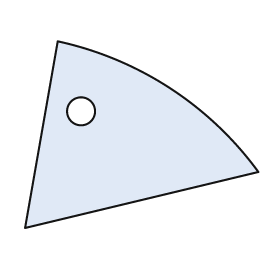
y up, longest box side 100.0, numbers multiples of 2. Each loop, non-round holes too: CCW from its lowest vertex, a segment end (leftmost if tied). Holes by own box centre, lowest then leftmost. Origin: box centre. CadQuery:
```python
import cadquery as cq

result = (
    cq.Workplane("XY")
    .moveTo(-50.0, -40.0)
    .lineTo(50.0, -16.0)
    .threePointArc((12.0, 20.0), (-36.0, 40.0))
    .close()
    .moveTo(-26.0, 10.0)
    .circle(6.0)
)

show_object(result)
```